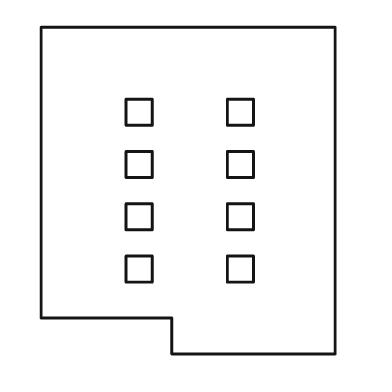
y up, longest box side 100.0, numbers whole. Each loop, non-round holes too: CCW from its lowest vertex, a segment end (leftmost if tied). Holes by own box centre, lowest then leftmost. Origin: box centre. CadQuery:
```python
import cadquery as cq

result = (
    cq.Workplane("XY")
    .moveTo(-5.0, -50.0)
    .lineTo(45.0, -50.0)
    .lineTo(45.0, 50.0)
    .lineTo(-45.0, 50.0)
    .lineTo(-45.0, -39.0)
    .lineTo(-5.0, -39.0)
    .close()
    .moveTo(-19.0, -28.0)
    .lineTo(-11.0, -28.0)
    .lineTo(-11.0, -20.0)
    .lineTo(-19.0, -20.0)
    .close()
    .moveTo(12.0, -28.0)
    .lineTo(20.0, -28.0)
    .lineTo(20.0, -20.0)
    .lineTo(12.0, -20.0)
    .close()
    .moveTo(-19.0, -12.0)
    .lineTo(-11.0, -12.0)
    .lineTo(-11.0, -4.0)
    .lineTo(-19.0, -4.0)
    .close()
    .moveTo(12.0, -12.0)
    .lineTo(20.0, -12.0)
    .lineTo(20.0, -4.0)
    .lineTo(12.0, -4.0)
    .close()
    .moveTo(-19.0, 4.0)
    .lineTo(-11.0, 4.0)
    .lineTo(-11.0, 12.0)
    .lineTo(-19.0, 12.0)
    .close()
    .moveTo(12.0, 4.0)
    .lineTo(20.0, 4.0)
    .lineTo(20.0, 12.0)
    .lineTo(12.0, 12.0)
    .close()
    .moveTo(-19.0, 20.0)
    .lineTo(-11.0, 20.0)
    .lineTo(-11.0, 28.0)
    .lineTo(-19.0, 28.0)
    .close()
    .moveTo(12.0, 20.0)
    .lineTo(20.0, 20.0)
    .lineTo(20.0, 28.0)
    .lineTo(12.0, 28.0)
    .close()
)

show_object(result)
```